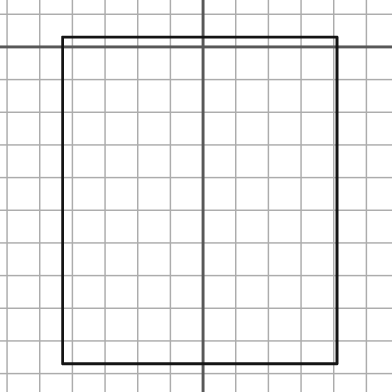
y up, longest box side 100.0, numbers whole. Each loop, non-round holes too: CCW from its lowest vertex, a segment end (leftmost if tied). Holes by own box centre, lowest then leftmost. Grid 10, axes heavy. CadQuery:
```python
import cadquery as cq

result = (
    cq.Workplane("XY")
    .moveTo(-43.0, -97.0)
    .lineTo(41.0, -97.0)
    .lineTo(41.0, 3.0)
    .lineTo(-43.0, 3.0)
    .close()
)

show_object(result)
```